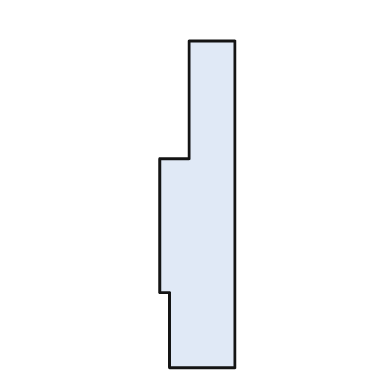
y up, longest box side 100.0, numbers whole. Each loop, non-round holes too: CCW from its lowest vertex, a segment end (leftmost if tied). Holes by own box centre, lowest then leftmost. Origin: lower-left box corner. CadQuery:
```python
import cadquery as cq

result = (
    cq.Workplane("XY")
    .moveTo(3.0, 0.0)
    .lineTo(23.0, 0.0)
    .lineTo(23.0, 100.0)
    .lineTo(9.0, 100.0)
    .lineTo(9.0, 64.0)
    .lineTo(0.0, 64.0)
    .lineTo(0.0, 23.0)
    .lineTo(3.0, 23.0)
    .close()
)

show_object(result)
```